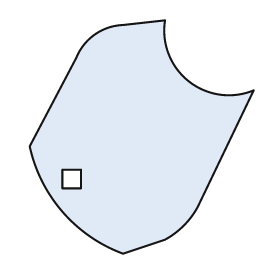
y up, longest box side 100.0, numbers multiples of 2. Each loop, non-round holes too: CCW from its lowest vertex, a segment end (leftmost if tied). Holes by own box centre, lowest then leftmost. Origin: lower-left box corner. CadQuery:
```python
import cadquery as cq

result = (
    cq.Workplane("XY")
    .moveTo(40.0, 0.0)
    .lineTo(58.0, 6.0)
    .threePointArc((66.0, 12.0), (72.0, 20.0))
    .lineTo(96.0, 70.0)
    .threePointArc((68.0, 74.0), (58.0, 100.0))
    .lineTo(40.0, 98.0)
    .threePointArc((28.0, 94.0), (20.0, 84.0))
    .lineTo(0.0, 46.0)
    .threePointArc((14.0, 18.0), (40.0, 0.0))
    .close()
    .moveTo(14.0, 28.0)
    .lineTo(22.0, 28.0)
    .lineTo(22.0, 36.0)
    .lineTo(14.0, 36.0)
    .close()
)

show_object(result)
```